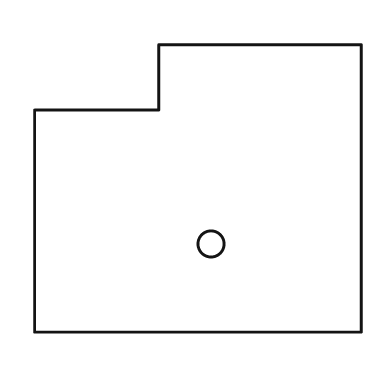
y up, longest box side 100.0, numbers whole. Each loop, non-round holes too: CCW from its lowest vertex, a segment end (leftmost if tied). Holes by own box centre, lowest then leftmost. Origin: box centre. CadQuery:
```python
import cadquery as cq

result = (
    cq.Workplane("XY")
    .moveTo(-50.0, -44.0)
    .lineTo(50.0, -44.0)
    .lineTo(50.0, 44.0)
    .lineTo(-12.0, 44.0)
    .lineTo(-12.0, 24.0)
    .lineTo(-50.0, 24.0)
    .close()
    .moveTo(4.0, -17.0)
    .circle(4.0)
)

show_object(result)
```